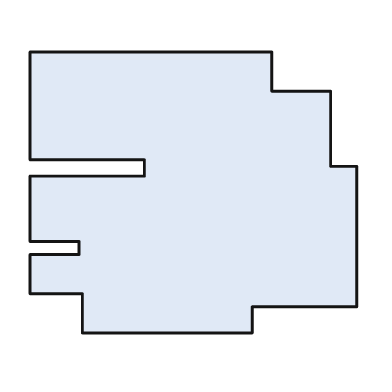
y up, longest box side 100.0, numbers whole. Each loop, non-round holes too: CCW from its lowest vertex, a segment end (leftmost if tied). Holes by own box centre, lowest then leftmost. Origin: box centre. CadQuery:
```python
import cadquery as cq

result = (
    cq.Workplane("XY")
    .moveTo(-34.0, -43.0)
    .lineTo(18.0, -43.0)
    .lineTo(18.0, -35.0)
    .lineTo(50.0, -35.0)
    .lineTo(50.0, 8.0)
    .lineTo(42.0, 8.0)
    .lineTo(42.0, 31.0)
    .lineTo(24.0, 31.0)
    .lineTo(24.0, 43.0)
    .lineTo(-50.0, 43.0)
    .lineTo(-50.0, 10.0)
    .lineTo(-15.0, 10.0)
    .lineTo(-15.0, 5.0)
    .lineTo(-50.0, 5.0)
    .lineTo(-50.0, -15.0)
    .lineTo(-35.0, -15.0)
    .lineTo(-35.0, -19.0)
    .lineTo(-50.0, -19.0)
    .lineTo(-50.0, -31.0)
    .lineTo(-34.0, -31.0)
    .close()
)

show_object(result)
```